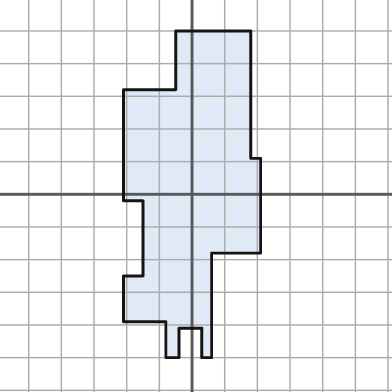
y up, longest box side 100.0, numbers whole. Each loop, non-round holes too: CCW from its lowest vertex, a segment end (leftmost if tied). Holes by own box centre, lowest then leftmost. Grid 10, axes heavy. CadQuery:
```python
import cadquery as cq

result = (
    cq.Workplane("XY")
    .moveTo(-8.0, -50.0)
    .lineTo(-4.0, -50.0)
    .lineTo(-4.0, -41.0)
    .lineTo(3.0, -41.0)
    .lineTo(3.0, -50.0)
    .lineTo(6.0, -50.0)
    .lineTo(6.0, -18.0)
    .lineTo(21.0, -18.0)
    .lineTo(21.0, 11.0)
    .lineTo(18.0, 11.0)
    .lineTo(18.0, 50.0)
    .lineTo(-5.0, 50.0)
    .lineTo(-5.0, 32.0)
    .lineTo(-21.0, 32.0)
    .lineTo(-21.0, -2.0)
    .lineTo(-15.0, -2.0)
    .lineTo(-15.0, -25.0)
    .lineTo(-21.0, -25.0)
    .lineTo(-21.0, -39.0)
    .lineTo(-8.0, -39.0)
    .close()
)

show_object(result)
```